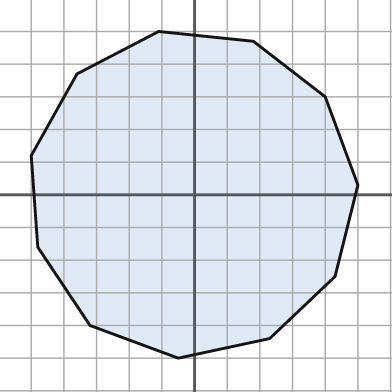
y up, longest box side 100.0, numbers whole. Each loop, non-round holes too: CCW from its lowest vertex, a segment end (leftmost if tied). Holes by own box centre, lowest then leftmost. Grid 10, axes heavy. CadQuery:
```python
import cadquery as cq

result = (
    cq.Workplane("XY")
    .moveTo(-5.0, -50.0)
    .lineTo(23.0, -44.0)
    .lineTo(43.0, -25.0)
    .lineTo(50.0, 3.0)
    .lineTo(40.0, 30.0)
    .lineTo(18.0, 47.0)
    .lineTo(-11.0, 50.0)
    .lineTo(-36.0, 37.0)
    .lineTo(-50.0, 12.0)
    .lineTo(-48.0, -16.0)
    .lineTo(-32.0, -40.0)
    .close()
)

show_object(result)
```